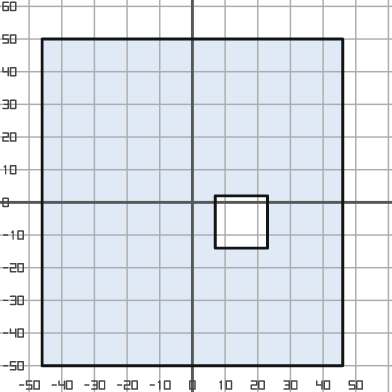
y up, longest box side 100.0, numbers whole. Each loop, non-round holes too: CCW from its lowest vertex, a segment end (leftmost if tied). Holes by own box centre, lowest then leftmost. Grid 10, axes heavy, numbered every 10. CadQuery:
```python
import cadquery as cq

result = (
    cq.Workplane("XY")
    .moveTo(-46.0, -50.0)
    .lineTo(46.0, -50.0)
    .lineTo(46.0, 50.0)
    .lineTo(-46.0, 50.0)
    .close()
    .moveTo(7.0, -14.0)
    .lineTo(23.0, -14.0)
    .lineTo(23.0, 2.0)
    .lineTo(7.0, 2.0)
    .close()
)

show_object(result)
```